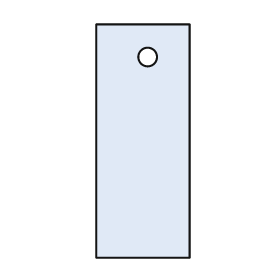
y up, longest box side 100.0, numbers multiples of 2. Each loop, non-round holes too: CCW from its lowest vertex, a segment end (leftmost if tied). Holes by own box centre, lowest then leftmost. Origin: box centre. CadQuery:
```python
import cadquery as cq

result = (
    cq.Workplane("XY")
    .moveTo(-20.0, -50.0)
    .lineTo(20.0, -50.0)
    .lineTo(20.0, 50.0)
    .lineTo(-20.0, 50.0)
    .close()
    .moveTo(2.0, 36.0)
    .circle(4.0)
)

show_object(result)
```